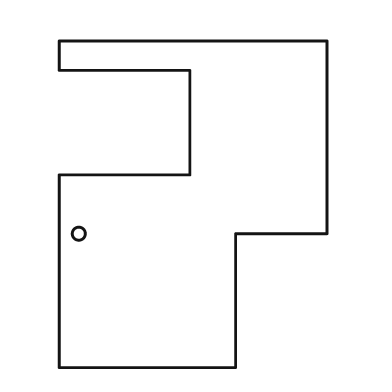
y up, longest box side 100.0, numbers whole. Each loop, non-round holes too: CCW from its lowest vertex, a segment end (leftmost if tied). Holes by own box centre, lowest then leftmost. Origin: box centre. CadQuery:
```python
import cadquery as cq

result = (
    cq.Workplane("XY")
    .moveTo(-41.0, -50.0)
    .lineTo(13.0, -50.0)
    .lineTo(13.0, -9.0)
    .lineTo(41.0, -9.0)
    .lineTo(41.0, 50.0)
    .lineTo(-41.0, 50.0)
    .lineTo(-41.0, 41.0)
    .lineTo(-1.0, 41.0)
    .lineTo(-1.0, 9.0)
    .lineTo(-41.0, 9.0)
    .close()
    .moveTo(-35.0, -9.0)
    .circle(2.0)
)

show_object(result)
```